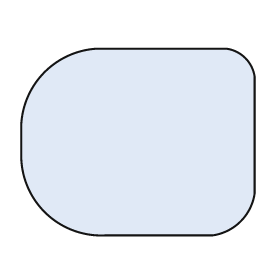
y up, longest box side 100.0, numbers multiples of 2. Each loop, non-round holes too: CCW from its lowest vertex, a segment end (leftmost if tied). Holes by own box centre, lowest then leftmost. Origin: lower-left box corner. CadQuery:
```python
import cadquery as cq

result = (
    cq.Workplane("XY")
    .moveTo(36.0, 0.0)
    .lineTo(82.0, 0.0)
    .threePointArc((94.0, 6.0), (100.0, 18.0))
    .lineTo(100.0, 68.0)
    .threePointArc((96.0, 76.0), (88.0, 80.0))
    .lineTo(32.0, 80.0)
    .threePointArc((10.0, 70.0), (0.0, 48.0))
    .lineTo(0.0, 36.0)
    .threePointArc((10.0, 10.0), (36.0, 0.0))
    .close()
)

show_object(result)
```